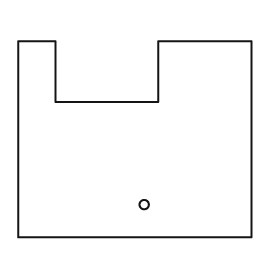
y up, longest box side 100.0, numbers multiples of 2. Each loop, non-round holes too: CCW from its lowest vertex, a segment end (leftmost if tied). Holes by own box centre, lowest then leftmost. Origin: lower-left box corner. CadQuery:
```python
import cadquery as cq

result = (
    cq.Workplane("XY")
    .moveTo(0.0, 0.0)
    .lineTo(100.0, 0.0)
    .lineTo(100.0, 84.0)
    .lineTo(60.0, 84.0)
    .lineTo(60.0, 58.0)
    .lineTo(16.0, 58.0)
    .lineTo(16.0, 84.0)
    .lineTo(0.0, 84.0)
    .close()
    .moveTo(54.0, 14.0)
    .circle(2.0)
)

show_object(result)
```